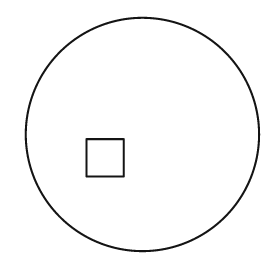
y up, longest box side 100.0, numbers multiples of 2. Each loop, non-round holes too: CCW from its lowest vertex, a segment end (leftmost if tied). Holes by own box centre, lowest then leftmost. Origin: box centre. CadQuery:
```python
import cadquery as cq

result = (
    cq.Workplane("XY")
    .moveTo(0.0, 0.0)
    .circle(50.0)
    .moveTo(-24.0, -18.0)
    .lineTo(-8.0, -18.0)
    .lineTo(-8.0, -2.0)
    .lineTo(-24.0, -2.0)
    .close()
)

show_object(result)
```